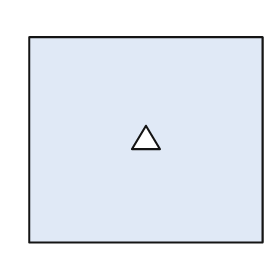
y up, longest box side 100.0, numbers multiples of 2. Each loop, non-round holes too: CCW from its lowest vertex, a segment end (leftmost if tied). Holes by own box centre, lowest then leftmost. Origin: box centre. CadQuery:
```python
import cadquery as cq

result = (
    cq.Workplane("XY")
    .moveTo(-50.0, -44.0)
    .lineTo(50.0, -44.0)
    .lineTo(50.0, 44.0)
    .lineTo(-50.0, 44.0)
    .close()
    .moveTo(-6.0, -4.0)
    .lineTo(6.0, -4.0)
    .lineTo(0.0, 6.0)
    .close()
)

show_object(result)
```